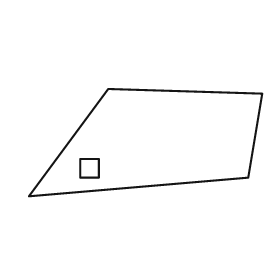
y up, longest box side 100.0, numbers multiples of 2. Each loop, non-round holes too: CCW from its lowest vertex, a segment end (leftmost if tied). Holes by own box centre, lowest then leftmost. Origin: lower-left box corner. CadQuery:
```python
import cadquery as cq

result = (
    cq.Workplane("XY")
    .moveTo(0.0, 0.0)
    .lineTo(94.0, 8.0)
    .lineTo(100.0, 44.0)
    .lineTo(34.0, 46.0)
    .close()
    .moveTo(22.0, 8.0)
    .lineTo(30.0, 8.0)
    .lineTo(30.0, 16.0)
    .lineTo(22.0, 16.0)
    .close()
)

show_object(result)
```